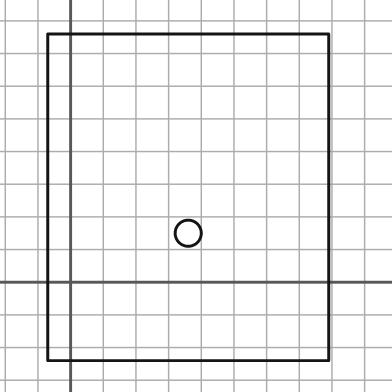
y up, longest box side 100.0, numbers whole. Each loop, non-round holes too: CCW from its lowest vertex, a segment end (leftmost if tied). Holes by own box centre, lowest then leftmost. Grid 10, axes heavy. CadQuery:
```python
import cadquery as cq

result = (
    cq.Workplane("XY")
    .moveTo(-7.0, -24.0)
    .lineTo(79.0, -24.0)
    .lineTo(79.0, 76.0)
    .lineTo(-7.0, 76.0)
    .close()
    .moveTo(36.0, 15.0)
    .circle(4.0)
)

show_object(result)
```